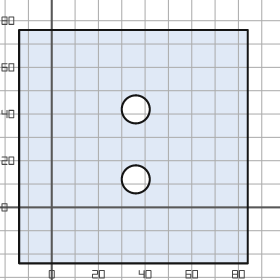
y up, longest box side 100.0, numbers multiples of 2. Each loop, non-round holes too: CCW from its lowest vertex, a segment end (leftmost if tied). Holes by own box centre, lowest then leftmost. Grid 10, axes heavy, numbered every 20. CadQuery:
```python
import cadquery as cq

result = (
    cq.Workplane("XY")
    .moveTo(-14.0, -24.0)
    .lineTo(84.0, -24.0)
    .lineTo(84.0, 76.0)
    .lineTo(-14.0, 76.0)
    .close()
    .moveTo(36.0, 12.0)
    .circle(6.0)
    .moveTo(36.0, 42.0)
    .circle(6.0)
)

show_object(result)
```